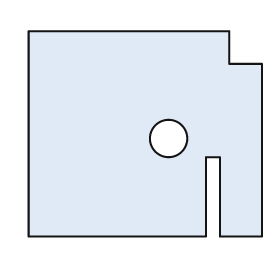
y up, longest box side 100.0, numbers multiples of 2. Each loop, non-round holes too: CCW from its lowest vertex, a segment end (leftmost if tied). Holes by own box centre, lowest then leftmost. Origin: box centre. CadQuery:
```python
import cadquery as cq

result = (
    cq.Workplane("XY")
    .moveTo(-50.0, -44.0)
    .lineTo(26.0, -44.0)
    .lineTo(26.0, -10.0)
    .lineTo(32.0, -10.0)
    .lineTo(32.0, -44.0)
    .lineTo(50.0, -44.0)
    .lineTo(50.0, 30.0)
    .lineTo(36.0, 30.0)
    .lineTo(36.0, 44.0)
    .lineTo(-50.0, 44.0)
    .close()
    .moveTo(10.0, -2.0)
    .circle(8.0)
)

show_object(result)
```